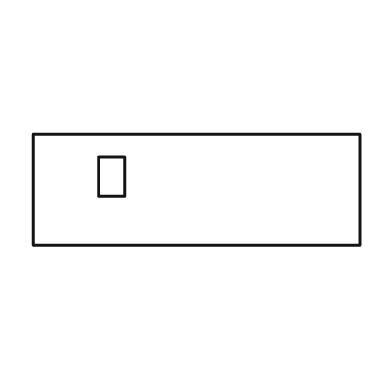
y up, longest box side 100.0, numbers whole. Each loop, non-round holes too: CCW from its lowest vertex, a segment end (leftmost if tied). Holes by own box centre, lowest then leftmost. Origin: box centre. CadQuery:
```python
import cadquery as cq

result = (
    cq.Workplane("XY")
    .moveTo(-50.0, -17.0)
    .lineTo(50.0, -17.0)
    .lineTo(50.0, 17.0)
    .lineTo(-50.0, 17.0)
    .close()
    .moveTo(-30.0, -2.0)
    .lineTo(-22.0, -2.0)
    .lineTo(-22.0, 10.0)
    .lineTo(-30.0, 10.0)
    .close()
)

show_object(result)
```